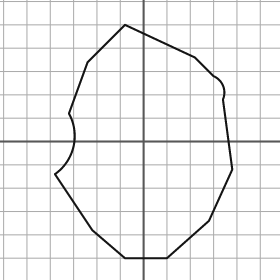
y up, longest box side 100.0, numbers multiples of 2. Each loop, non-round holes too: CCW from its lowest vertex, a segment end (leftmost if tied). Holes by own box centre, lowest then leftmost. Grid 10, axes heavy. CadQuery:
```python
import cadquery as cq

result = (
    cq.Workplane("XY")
    .moveTo(-8.0, -50.0)
    .lineTo(10.0, -50.0)
    .lineTo(28.0, -34.0)
    .lineTo(38.0, -12.0)
    .lineTo(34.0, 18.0)
    .threePointArc((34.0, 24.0), (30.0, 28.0))
    .lineTo(22.0, 36.0)
    .lineTo(-8.0, 50.0)
    .lineTo(-24.0, 34.0)
    .lineTo(-32.0, 12.0)
    .threePointArc((-30.0, -2.0), (-38.0, -14.0))
    .lineTo(-22.0, -38.0)
    .close()
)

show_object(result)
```